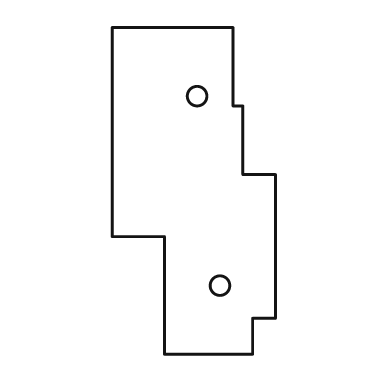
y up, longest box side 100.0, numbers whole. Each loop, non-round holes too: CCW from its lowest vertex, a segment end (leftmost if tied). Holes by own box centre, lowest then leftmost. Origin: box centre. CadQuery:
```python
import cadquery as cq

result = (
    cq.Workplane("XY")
    .moveTo(-9.0, -50.0)
    .lineTo(18.0, -50.0)
    .lineTo(18.0, -39.0)
    .lineTo(25.0, -39.0)
    .lineTo(25.0, 5.0)
    .lineTo(15.0, 5.0)
    .lineTo(15.0, 26.0)
    .lineTo(12.0, 26.0)
    .lineTo(12.0, 50.0)
    .lineTo(-25.0, 50.0)
    .lineTo(-25.0, -14.0)
    .lineTo(-9.0, -14.0)
    .close()
    .moveTo(8.0, -29.0)
    .circle(3.0)
    .moveTo(1.0, 29.0)
    .circle(3.0)
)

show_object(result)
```